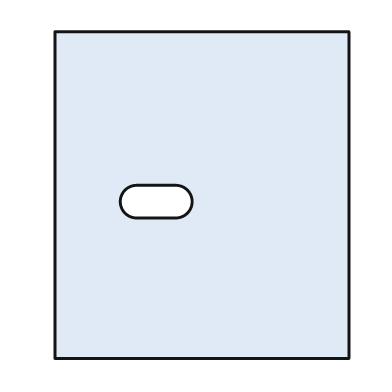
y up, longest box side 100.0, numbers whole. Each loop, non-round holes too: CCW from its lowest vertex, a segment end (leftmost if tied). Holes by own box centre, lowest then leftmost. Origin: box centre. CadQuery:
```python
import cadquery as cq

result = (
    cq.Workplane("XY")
    .moveTo(-45.0, -50.0)
    .lineTo(45.0, -50.0)
    .lineTo(45.0, 50.0)
    .lineTo(-45.0, 50.0)
    .close()
    .moveTo(-20.0, -7.0)
    .lineTo(-8.0, -7.0)
    .threePointArc((-3.0, -2.0), (-8.0, 3.0))
    .lineTo(-20.0, 3.0)
    .threePointArc((-25.0, -2.0), (-20.0, -7.0))
    .close()
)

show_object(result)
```